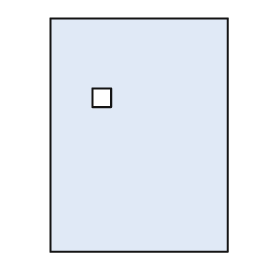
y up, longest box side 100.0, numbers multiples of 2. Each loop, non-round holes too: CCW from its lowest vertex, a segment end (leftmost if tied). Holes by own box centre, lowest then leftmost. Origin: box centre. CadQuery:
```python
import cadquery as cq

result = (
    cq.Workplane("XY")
    .moveTo(-38.0, -50.0)
    .lineTo(38.0, -50.0)
    .lineTo(38.0, 50.0)
    .lineTo(-38.0, 50.0)
    .close()
    .moveTo(-20.0, 12.0)
    .lineTo(-12.0, 12.0)
    .lineTo(-12.0, 20.0)
    .lineTo(-20.0, 20.0)
    .close()
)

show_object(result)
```